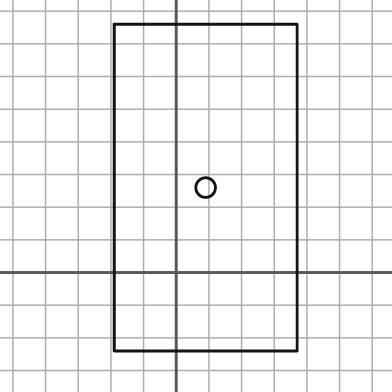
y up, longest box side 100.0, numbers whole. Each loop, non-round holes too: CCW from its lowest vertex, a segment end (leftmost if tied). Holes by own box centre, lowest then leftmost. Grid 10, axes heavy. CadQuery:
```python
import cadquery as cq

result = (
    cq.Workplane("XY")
    .moveTo(-19.0, -24.0)
    .lineTo(37.0, -24.0)
    .lineTo(37.0, 76.0)
    .lineTo(-19.0, 76.0)
    .close()
    .moveTo(9.0, 26.0)
    .circle(3.0)
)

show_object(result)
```